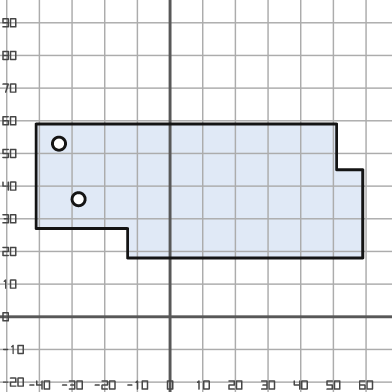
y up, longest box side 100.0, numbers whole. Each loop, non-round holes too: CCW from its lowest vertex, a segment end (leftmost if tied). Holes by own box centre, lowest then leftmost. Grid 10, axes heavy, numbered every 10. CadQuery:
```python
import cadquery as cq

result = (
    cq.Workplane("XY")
    .moveTo(-13.0, 18.0)
    .lineTo(59.0, 18.0)
    .lineTo(59.0, 45.0)
    .lineTo(51.0, 45.0)
    .lineTo(51.0, 59.0)
    .lineTo(-41.0, 59.0)
    .lineTo(-41.0, 27.0)
    .lineTo(-13.0, 27.0)
    .close()
    .moveTo(-28.0, 36.0)
    .circle(2.0)
    .moveTo(-34.0, 53.0)
    .circle(2.0)
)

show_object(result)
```